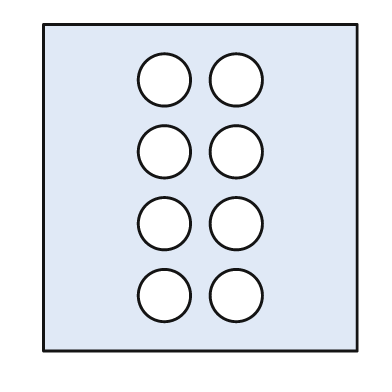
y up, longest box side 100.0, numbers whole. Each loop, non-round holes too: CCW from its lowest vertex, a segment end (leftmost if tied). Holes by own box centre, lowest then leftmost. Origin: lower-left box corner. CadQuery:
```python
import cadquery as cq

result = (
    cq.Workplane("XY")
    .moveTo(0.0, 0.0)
    .lineTo(96.0, 0.0)
    .lineTo(96.0, 100.0)
    .lineTo(0.0, 100.0)
    .close()
    .moveTo(37.0, 17.0)
    .circle(8.0)
    .moveTo(59.0, 17.0)
    .circle(8.0)
    .moveTo(37.0, 39.0)
    .circle(8.0)
    .moveTo(59.0, 39.0)
    .circle(8.0)
    .moveTo(37.0, 61.0)
    .circle(8.0)
    .moveTo(59.0, 61.0)
    .circle(8.0)
    .moveTo(37.0, 83.0)
    .circle(8.0)
    .moveTo(59.0, 83.0)
    .circle(8.0)
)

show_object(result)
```